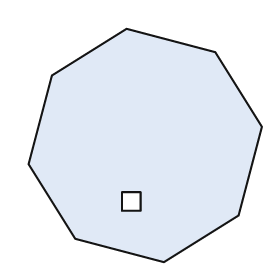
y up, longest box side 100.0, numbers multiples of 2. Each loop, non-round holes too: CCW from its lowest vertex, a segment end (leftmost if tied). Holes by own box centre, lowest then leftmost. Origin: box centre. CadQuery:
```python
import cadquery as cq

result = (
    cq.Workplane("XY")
    .moveTo(8.0, -50.0)
    .lineTo(40.0, -30.0)
    .lineTo(50.0, 8.0)
    .lineTo(30.0, 40.0)
    .lineTo(-8.0, 50.0)
    .lineTo(-40.0, 30.0)
    .lineTo(-50.0, -8.0)
    .lineTo(-30.0, -40.0)
    .close()
    .moveTo(-10.0, -28.0)
    .lineTo(-2.0, -28.0)
    .lineTo(-2.0, -20.0)
    .lineTo(-10.0, -20.0)
    .close()
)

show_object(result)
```